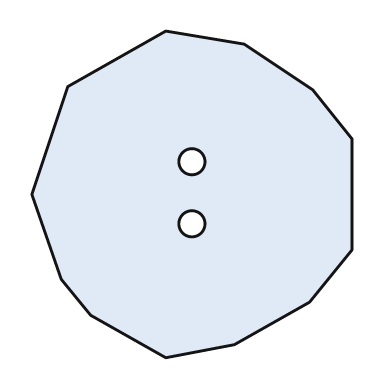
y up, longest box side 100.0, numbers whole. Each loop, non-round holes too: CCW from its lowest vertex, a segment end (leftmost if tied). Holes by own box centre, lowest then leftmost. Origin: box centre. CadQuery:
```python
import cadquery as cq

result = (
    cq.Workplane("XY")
    .moveTo(-8.0, -50.0)
    .lineTo(13.0, -46.0)
    .lineTo(36.0, -33.0)
    .lineTo(49.0, -17.0)
    .lineTo(49.0, 17.0)
    .lineTo(37.0, 32.0)
    .lineTo(16.0, 46.0)
    .lineTo(-8.0, 50.0)
    .lineTo(-38.0, 33.0)
    .lineTo(-49.0, 0.0)
    .lineTo(-40.0, -26.0)
    .lineTo(-31.0, -37.0)
    .close()
    .moveTo(0.0, -9.0)
    .circle(4.0)
    .moveTo(0.0, 10.0)
    .circle(4.0)
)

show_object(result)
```